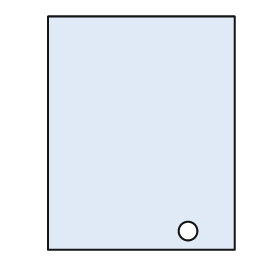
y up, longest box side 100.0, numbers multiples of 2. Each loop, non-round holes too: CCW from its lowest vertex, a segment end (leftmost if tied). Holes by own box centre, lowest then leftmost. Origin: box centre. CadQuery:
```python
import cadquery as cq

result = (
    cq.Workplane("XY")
    .moveTo(-40.0, -50.0)
    .lineTo(40.0, -50.0)
    .lineTo(40.0, 50.0)
    .lineTo(-40.0, 50.0)
    .close()
    .moveTo(20.0, -42.0)
    .circle(4.0)
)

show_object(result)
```